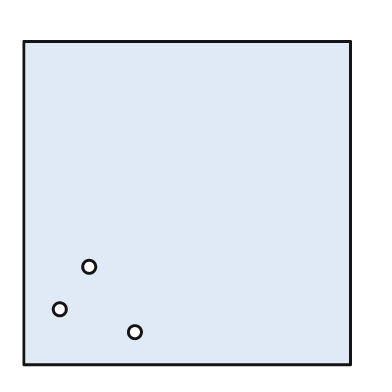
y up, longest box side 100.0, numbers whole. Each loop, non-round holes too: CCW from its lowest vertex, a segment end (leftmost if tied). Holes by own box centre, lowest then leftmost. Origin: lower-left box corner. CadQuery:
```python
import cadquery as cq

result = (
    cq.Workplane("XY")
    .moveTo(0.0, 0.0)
    .lineTo(100.0, 0.0)
    .lineTo(100.0, 99.0)
    .lineTo(0.0, 99.0)
    .close()
    .moveTo(34.0, 10.0)
    .circle(2.0)
    .moveTo(11.0, 17.0)
    .circle(2.0)
    .moveTo(20.0, 30.0)
    .circle(2.0)
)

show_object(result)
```